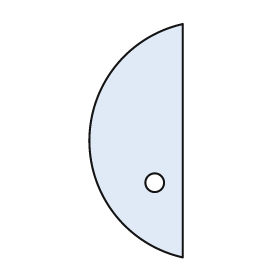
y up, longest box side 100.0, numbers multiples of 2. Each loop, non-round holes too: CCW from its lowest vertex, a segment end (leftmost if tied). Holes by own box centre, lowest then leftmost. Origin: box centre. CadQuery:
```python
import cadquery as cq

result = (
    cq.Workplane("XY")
    .moveTo(20.0, -50.0)
    .lineTo(20.0, 50.0)
    .threePointArc((-20.0, 0.0), (20.0, -50.0))
    .close()
    .moveTo(8.0, -18.0)
    .circle(4.0)
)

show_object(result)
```